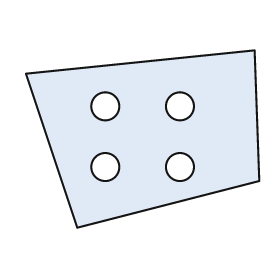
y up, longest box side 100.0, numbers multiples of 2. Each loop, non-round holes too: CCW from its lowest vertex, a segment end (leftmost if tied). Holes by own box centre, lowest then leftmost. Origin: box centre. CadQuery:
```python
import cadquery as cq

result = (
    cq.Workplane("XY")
    .moveTo(-28.0, -38.0)
    .lineTo(50.0, -18.0)
    .lineTo(48.0, 38.0)
    .lineTo(-50.0, 28.0)
    .close()
    .moveTo(-16.0, -12.0)
    .circle(6.0)
    .moveTo(16.0, -12.0)
    .circle(6.0)
    .moveTo(-16.0, 14.0)
    .circle(6.0)
    .moveTo(16.0, 14.0)
    .circle(6.0)
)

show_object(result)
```